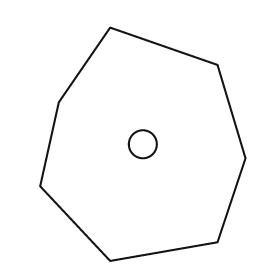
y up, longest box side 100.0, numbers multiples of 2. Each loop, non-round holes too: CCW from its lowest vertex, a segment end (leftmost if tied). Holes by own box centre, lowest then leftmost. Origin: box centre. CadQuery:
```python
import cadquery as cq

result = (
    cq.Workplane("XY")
    .moveTo(-14.0, -50.0)
    .lineTo(32.0, -42.0)
    .lineTo(44.0, -6.0)
    .lineTo(32.0, 34.0)
    .lineTo(-14.0, 50.0)
    .lineTo(-36.0, 18.0)
    .lineTo(-44.0, -18.0)
    .close()
    .moveTo(0.0, 0.0)
    .circle(6.0)
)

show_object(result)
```